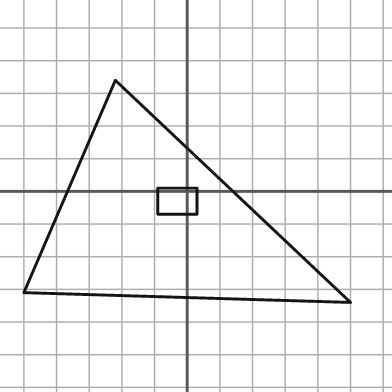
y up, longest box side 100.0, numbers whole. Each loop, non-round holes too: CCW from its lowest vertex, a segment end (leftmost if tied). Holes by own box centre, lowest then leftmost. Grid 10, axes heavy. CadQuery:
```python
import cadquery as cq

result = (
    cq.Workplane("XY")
    .moveTo(50.0, -34.0)
    .lineTo(-22.0, 34.0)
    .lineTo(-50.0, -31.0)
    .close()
    .moveTo(-9.0, -7.0)
    .lineTo(3.0, -7.0)
    .lineTo(3.0, 1.0)
    .lineTo(-9.0, 1.0)
    .close()
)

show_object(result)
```